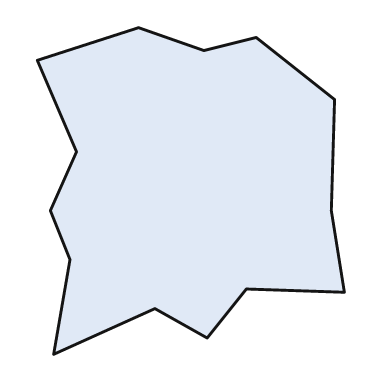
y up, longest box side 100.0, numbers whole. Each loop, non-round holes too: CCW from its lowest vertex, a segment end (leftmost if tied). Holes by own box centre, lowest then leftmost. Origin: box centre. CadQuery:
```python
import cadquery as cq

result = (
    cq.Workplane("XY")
    .moveTo(-42.0, -50.0)
    .lineTo(-11.0, -36.0)
    .lineTo(5.0, -45.0)
    .lineTo(17.0, -30.0)
    .lineTo(47.0, -31.0)
    .lineTo(43.0, -6.0)
    .lineTo(44.0, 28.0)
    .lineTo(20.0, 47.0)
    .lineTo(4.0, 43.0)
    .lineTo(-16.0, 50.0)
    .lineTo(-47.0, 40.0)
    .lineTo(-35.0, 12.0)
    .lineTo(-43.0, -6.0)
    .lineTo(-37.0, -21.0)
    .close()
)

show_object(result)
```